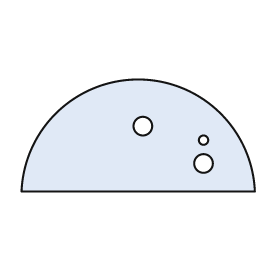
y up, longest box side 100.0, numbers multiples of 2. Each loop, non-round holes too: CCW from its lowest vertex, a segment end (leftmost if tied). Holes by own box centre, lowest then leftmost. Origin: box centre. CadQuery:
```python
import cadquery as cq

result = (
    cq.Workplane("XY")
    .moveTo(-50.0, -24.0)
    .lineTo(50.0, -24.0)
    .threePointArc((0.0, 24.0), (-50.0, -24.0))
    .close()
    .moveTo(28.0, -12.0)
    .circle(4.0)
    .moveTo(28.0, -2.0)
    .circle(2.0)
    .moveTo(2.0, 4.0)
    .circle(4.0)
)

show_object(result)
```